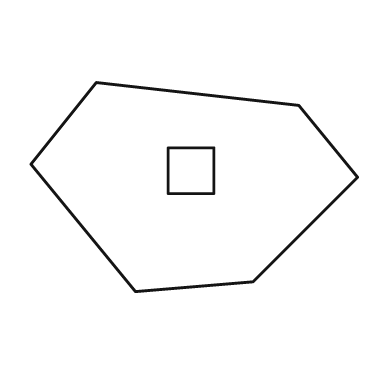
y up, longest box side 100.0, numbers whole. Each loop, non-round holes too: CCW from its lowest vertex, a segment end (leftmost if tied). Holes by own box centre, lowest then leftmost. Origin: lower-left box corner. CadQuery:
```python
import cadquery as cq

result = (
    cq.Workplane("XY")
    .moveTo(32.0, 0.0)
    .lineTo(68.0, 3.0)
    .lineTo(100.0, 35.0)
    .lineTo(82.0, 57.0)
    .lineTo(20.0, 64.0)
    .lineTo(0.0, 39.0)
    .close()
    .moveTo(42.0, 30.0)
    .lineTo(56.0, 30.0)
    .lineTo(56.0, 44.0)
    .lineTo(42.0, 44.0)
    .close()
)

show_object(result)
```